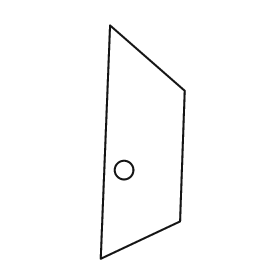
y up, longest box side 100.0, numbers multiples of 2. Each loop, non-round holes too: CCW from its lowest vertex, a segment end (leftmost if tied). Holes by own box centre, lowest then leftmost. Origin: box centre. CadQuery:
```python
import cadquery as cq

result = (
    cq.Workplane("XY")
    .moveTo(-18.0, -50.0)
    .lineTo(16.0, -34.0)
    .lineTo(18.0, 22.0)
    .lineTo(-14.0, 50.0)
    .close()
    .moveTo(-8.0, -12.0)
    .circle(4.0)
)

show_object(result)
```